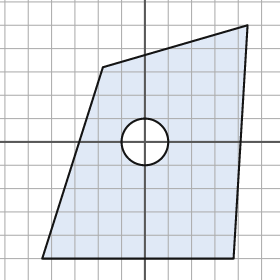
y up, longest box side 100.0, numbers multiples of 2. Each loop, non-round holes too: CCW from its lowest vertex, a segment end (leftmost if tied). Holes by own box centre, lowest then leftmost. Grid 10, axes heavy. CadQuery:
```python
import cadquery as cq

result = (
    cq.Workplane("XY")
    .moveTo(-44.0, -50.0)
    .lineTo(38.0, -50.0)
    .lineTo(44.0, 50.0)
    .lineTo(-18.0, 32.0)
    .close()
    .moveTo(0.0, 0.0)
    .circle(10.0)
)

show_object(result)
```